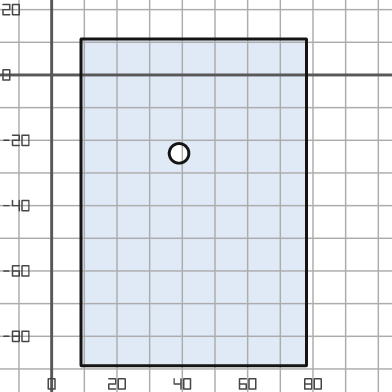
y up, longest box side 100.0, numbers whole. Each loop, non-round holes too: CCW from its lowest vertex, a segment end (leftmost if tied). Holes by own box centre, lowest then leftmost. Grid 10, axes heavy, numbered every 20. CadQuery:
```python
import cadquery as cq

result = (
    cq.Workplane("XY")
    .moveTo(9.0, -89.0)
    .lineTo(78.0, -89.0)
    .lineTo(78.0, 11.0)
    .lineTo(9.0, 11.0)
    .close()
    .moveTo(39.0, -24.0)
    .circle(3.0)
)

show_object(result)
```